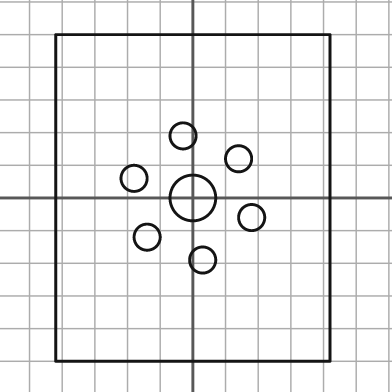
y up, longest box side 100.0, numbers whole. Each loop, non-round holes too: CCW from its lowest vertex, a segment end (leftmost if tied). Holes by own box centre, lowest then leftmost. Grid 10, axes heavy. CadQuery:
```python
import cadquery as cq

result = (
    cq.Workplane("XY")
    .moveTo(-42.0, -50.0)
    .lineTo(42.0, -50.0)
    .lineTo(42.0, 50.0)
    .lineTo(-42.0, 50.0)
    .close()
    .moveTo(3.0, -19.0)
    .circle(4.0)
    .moveTo(-14.0, -12.0)
    .circle(4.0)
    .moveTo(18.0, -6.0)
    .circle(4.0)
    .moveTo(0.0, 0.0)
    .circle(7.0)
    .moveTo(-18.0, 6.0)
    .circle(4.0)
    .moveTo(14.0, 12.0)
    .circle(4.0)
    .moveTo(-3.0, 19.0)
    .circle(4.0)
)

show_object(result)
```